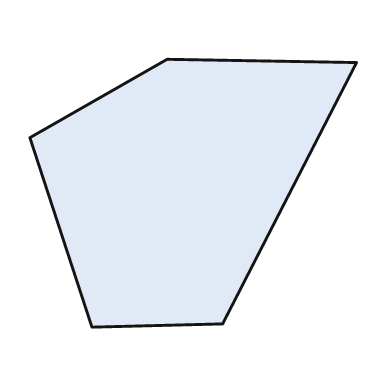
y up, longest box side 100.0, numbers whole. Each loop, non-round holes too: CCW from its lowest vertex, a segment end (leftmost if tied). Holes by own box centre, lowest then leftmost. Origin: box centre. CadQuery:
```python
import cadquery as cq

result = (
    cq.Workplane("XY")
    .moveTo(-31.0, -41.0)
    .lineTo(9.0, -40.0)
    .lineTo(50.0, 40.0)
    .lineTo(-8.0, 41.0)
    .lineTo(-50.0, 17.0)
    .close()
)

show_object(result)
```